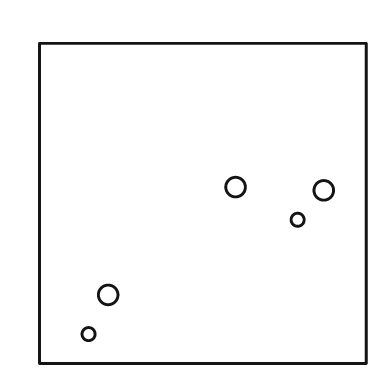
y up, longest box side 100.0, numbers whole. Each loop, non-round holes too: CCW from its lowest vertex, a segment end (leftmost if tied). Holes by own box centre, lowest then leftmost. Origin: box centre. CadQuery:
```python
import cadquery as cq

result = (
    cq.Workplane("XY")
    .moveTo(-50.0, -49.0)
    .lineTo(50.0, -49.0)
    .lineTo(50.0, 49.0)
    .lineTo(-50.0, 49.0)
    .close()
    .moveTo(-35.0, -40.0)
    .circle(2.0)
    .moveTo(-29.0, -28.0)
    .circle(3.0)
    .moveTo(29.0, -5.0)
    .circle(2.0)
    .moveTo(37.0, 4.0)
    .circle(3.0)
    .moveTo(10.0, 5.0)
    .circle(3.0)
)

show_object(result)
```